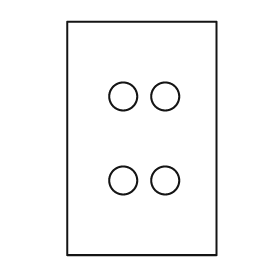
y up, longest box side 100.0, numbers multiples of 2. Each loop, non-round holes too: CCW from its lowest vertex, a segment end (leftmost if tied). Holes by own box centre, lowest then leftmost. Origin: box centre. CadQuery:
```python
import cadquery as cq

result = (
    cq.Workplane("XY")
    .moveTo(-32.0, -50.0)
    .lineTo(32.0, -50.0)
    .lineTo(32.0, 50.0)
    .lineTo(-32.0, 50.0)
    .close()
    .moveTo(-8.0, -18.0)
    .circle(6.0)
    .moveTo(10.0, -18.0)
    .circle(6.0)
    .moveTo(-8.0, 18.0)
    .circle(6.0)
    .moveTo(10.0, 18.0)
    .circle(6.0)
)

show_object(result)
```